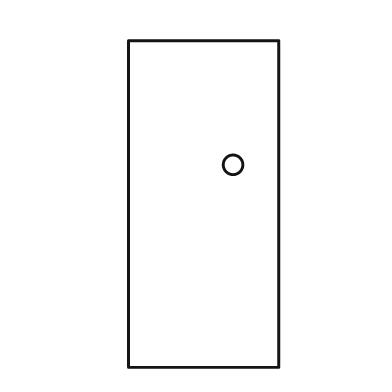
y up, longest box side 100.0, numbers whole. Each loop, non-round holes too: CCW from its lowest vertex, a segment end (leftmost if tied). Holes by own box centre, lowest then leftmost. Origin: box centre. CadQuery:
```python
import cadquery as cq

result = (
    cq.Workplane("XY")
    .moveTo(-23.0, -50.0)
    .lineTo(23.0, -50.0)
    .lineTo(23.0, 50.0)
    .lineTo(-23.0, 50.0)
    .close()
    .moveTo(9.0, 12.0)
    .circle(3.0)
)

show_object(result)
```